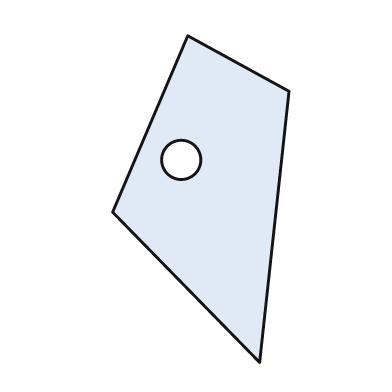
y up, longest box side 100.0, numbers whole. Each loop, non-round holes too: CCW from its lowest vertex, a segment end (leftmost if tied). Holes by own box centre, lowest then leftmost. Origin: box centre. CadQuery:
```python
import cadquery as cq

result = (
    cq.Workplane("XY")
    .moveTo(18.0, -50.0)
    .lineTo(27.0, 33.0)
    .lineTo(-4.0, 50.0)
    .lineTo(-27.0, -4.0)
    .close()
    .moveTo(-6.0, 12.0)
    .circle(6.0)
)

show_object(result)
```